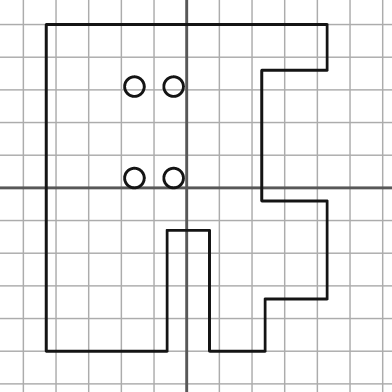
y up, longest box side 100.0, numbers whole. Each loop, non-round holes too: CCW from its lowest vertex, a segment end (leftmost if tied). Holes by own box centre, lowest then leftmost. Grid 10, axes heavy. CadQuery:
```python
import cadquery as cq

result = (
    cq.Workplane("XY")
    .moveTo(-43.0, -50.0)
    .lineTo(-6.0, -50.0)
    .lineTo(-6.0, -13.0)
    .lineTo(7.0, -13.0)
    .lineTo(7.0, -50.0)
    .lineTo(24.0, -50.0)
    .lineTo(24.0, -34.0)
    .lineTo(43.0, -34.0)
    .lineTo(43.0, -4.0)
    .lineTo(23.0, -4.0)
    .lineTo(23.0, 36.0)
    .lineTo(43.0, 36.0)
    .lineTo(43.0, 50.0)
    .lineTo(-43.0, 50.0)
    .close()
    .moveTo(-16.0, 3.0)
    .circle(3.0)
    .moveTo(-4.0, 3.0)
    .circle(3.0)
    .moveTo(-16.0, 31.0)
    .circle(3.0)
    .moveTo(-4.0, 31.0)
    .circle(3.0)
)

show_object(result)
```